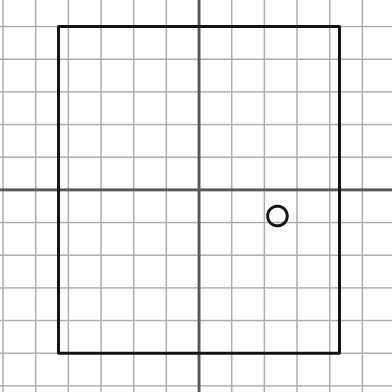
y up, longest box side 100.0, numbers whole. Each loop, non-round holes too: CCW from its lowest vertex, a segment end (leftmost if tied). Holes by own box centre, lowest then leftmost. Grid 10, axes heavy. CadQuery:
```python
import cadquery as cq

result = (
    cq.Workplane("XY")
    .moveTo(-43.0, -50.0)
    .lineTo(43.0, -50.0)
    .lineTo(43.0, 50.0)
    .lineTo(-43.0, 50.0)
    .close()
    .moveTo(24.0, -8.0)
    .circle(3.0)
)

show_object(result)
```